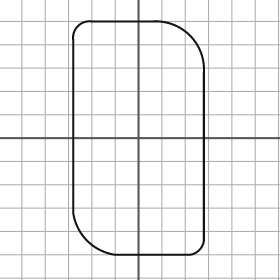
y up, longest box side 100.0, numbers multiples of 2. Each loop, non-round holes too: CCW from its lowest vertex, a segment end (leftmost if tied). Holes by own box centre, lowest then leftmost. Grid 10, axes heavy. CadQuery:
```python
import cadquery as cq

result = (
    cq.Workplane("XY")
    .moveTo(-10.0, -50.0)
    .lineTo(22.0, -50.0)
    .threePointArc((26.0, -48.0), (28.0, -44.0))
    .lineTo(28.0, 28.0)
    .threePointArc((22.0, 44.0), (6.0, 50.0))
    .lineTo(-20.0, 50.0)
    .threePointArc((-26.0, 48.0), (-28.0, 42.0))
    .lineTo(-28.0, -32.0)
    .threePointArc((-22.0, -44.0), (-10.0, -50.0))
    .close()
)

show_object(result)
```